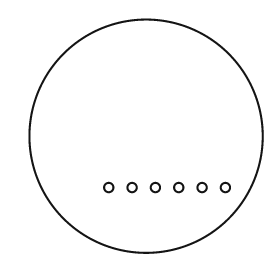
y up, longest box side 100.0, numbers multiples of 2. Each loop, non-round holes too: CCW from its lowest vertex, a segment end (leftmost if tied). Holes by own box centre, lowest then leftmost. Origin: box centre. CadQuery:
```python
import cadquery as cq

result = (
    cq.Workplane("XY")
    .moveTo(0.0, 0.0)
    .circle(50.0)
    .moveTo(-16.0, -22.0)
    .circle(2.0)
    .moveTo(-6.0, -22.0)
    .circle(2.0)
    .moveTo(4.0, -22.0)
    .circle(2.0)
    .moveTo(14.0, -22.0)
    .circle(2.0)
    .moveTo(24.0, -22.0)
    .circle(2.0)
    .moveTo(34.0, -22.0)
    .circle(2.0)
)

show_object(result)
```